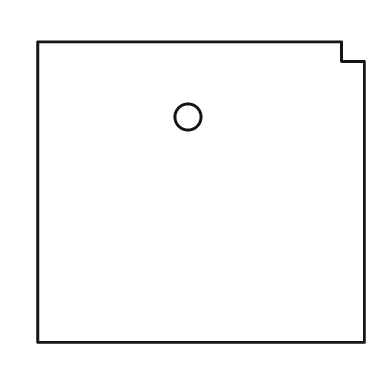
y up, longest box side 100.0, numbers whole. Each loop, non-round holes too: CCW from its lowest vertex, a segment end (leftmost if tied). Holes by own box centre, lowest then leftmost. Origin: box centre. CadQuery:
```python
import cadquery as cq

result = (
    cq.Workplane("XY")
    .moveTo(-50.0, -46.0)
    .lineTo(50.0, -46.0)
    .lineTo(50.0, 40.0)
    .lineTo(43.0, 40.0)
    .lineTo(43.0, 46.0)
    .lineTo(-50.0, 46.0)
    .close()
    .moveTo(-4.0, 23.0)
    .circle(4.0)
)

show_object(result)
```